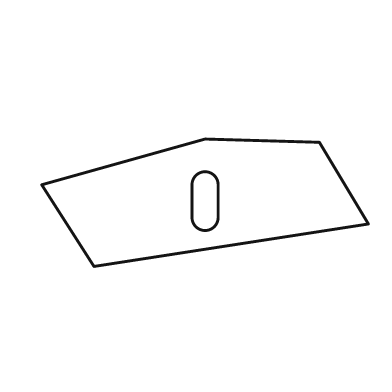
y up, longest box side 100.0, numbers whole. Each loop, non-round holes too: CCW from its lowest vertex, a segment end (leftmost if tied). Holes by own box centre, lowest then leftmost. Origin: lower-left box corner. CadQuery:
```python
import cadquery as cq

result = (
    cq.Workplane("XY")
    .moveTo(16.0, 0.0)
    .lineTo(100.0, 13.0)
    .lineTo(85.0, 38.0)
    .lineTo(50.0, 39.0)
    .lineTo(0.0, 25.0)
    .close()
    .moveTo(46.0, 15.0)
    .threePointArc((50.0, 11.0), (54.0, 15.0))
    .lineTo(54.0, 25.0)
    .threePointArc((50.0, 29.0), (46.0, 25.0))
    .close()
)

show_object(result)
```